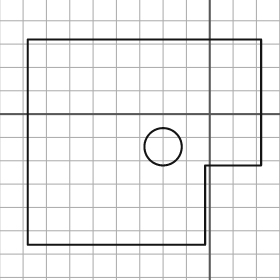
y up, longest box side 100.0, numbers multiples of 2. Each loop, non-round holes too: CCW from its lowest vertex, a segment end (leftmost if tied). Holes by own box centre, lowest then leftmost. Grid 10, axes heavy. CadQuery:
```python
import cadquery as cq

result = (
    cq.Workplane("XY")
    .moveTo(-78.0, -56.0)
    .lineTo(-2.0, -56.0)
    .lineTo(-2.0, -22.0)
    .lineTo(22.0, -22.0)
    .lineTo(22.0, 32.0)
    .lineTo(-78.0, 32.0)
    .close()
    .moveTo(-20.0, -14.0)
    .circle(8.0)
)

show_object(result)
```